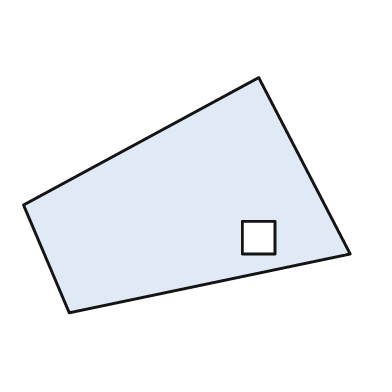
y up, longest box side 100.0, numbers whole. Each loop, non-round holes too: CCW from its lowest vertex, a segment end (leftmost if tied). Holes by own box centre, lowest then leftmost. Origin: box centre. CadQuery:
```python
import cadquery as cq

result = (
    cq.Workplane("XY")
    .moveTo(-36.0, -36.0)
    .lineTo(50.0, -18.0)
    .lineTo(22.0, 36.0)
    .lineTo(-50.0, -3.0)
    .close()
    .moveTo(17.0, -18.0)
    .lineTo(27.0, -18.0)
    .lineTo(27.0, -8.0)
    .lineTo(17.0, -8.0)
    .close()
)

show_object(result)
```